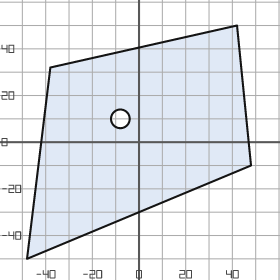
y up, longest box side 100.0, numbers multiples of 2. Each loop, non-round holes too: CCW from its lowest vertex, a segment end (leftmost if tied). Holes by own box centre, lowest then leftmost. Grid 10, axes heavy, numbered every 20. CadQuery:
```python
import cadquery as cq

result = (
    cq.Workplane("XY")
    .moveTo(-48.0, -50.0)
    .lineTo(48.0, -10.0)
    .lineTo(42.0, 50.0)
    .lineTo(-38.0, 32.0)
    .close()
    .moveTo(-8.0, 10.0)
    .circle(4.0)
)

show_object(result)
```